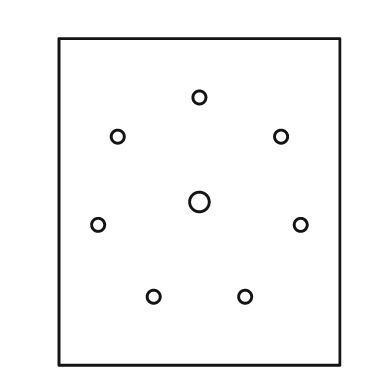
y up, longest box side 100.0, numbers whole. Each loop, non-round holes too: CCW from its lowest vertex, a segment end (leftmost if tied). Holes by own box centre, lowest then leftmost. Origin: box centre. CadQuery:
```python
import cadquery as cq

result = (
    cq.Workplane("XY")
    .moveTo(-43.0, -50.0)
    .lineTo(43.0, -50.0)
    .lineTo(43.0, 50.0)
    .lineTo(-43.0, 50.0)
    .close()
    .moveTo(-14.0, -29.0)
    .circle(2.0)
    .moveTo(14.0, -29.0)
    .circle(2.0)
    .moveTo(-31.0, -7.0)
    .circle(2.0)
    .moveTo(31.0, -7.0)
    .circle(2.0)
    .moveTo(0.0, 0.0)
    .circle(3.0)
    .moveTo(-25.0, 20.0)
    .circle(2.0)
    .moveTo(25.0, 20.0)
    .circle(2.0)
    .moveTo(0.0, 32.0)
    .circle(2.0)
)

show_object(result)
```